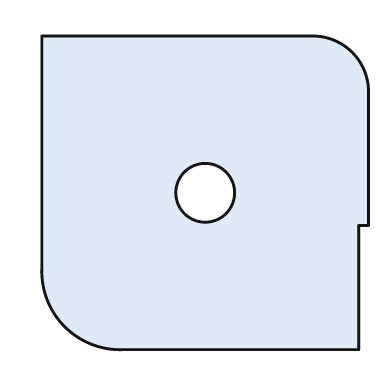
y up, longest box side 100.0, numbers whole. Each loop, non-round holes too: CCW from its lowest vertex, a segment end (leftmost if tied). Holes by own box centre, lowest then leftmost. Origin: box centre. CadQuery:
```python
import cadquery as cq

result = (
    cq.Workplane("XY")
    .moveTo(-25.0, -48.0)
    .lineTo(47.0, -48.0)
    .lineTo(47.0, -10.0)
    .lineTo(50.0, -10.0)
    .lineTo(50.0, 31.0)
    .threePointArc((45.0, 43.0), (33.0, 48.0))
    .lineTo(-50.0, 48.0)
    .lineTo(-50.0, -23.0)
    .threePointArc((-43.0, -41.0), (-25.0, -48.0))
    .close()
    .moveTo(0.0, 0.0)
    .circle(9.0)
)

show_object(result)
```